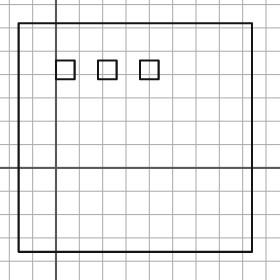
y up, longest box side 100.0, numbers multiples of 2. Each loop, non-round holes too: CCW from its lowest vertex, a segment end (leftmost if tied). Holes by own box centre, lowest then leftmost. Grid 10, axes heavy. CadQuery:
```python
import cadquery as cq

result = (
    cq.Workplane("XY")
    .moveTo(-16.0, -36.0)
    .lineTo(84.0, -36.0)
    .lineTo(84.0, 62.0)
    .lineTo(-16.0, 62.0)
    .close()
    .moveTo(0.0, 38.0)
    .lineTo(8.0, 38.0)
    .lineTo(8.0, 46.0)
    .lineTo(0.0, 46.0)
    .close()
    .moveTo(18.0, 38.0)
    .lineTo(26.0, 38.0)
    .lineTo(26.0, 46.0)
    .lineTo(18.0, 46.0)
    .close()
    .moveTo(36.0, 38.0)
    .lineTo(44.0, 38.0)
    .lineTo(44.0, 46.0)
    .lineTo(36.0, 46.0)
    .close()
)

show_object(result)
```